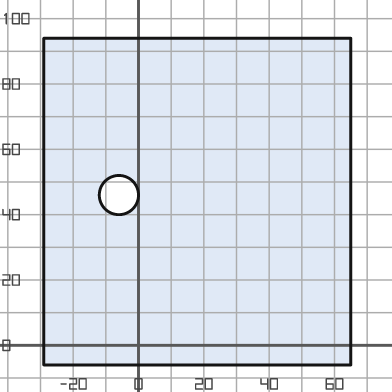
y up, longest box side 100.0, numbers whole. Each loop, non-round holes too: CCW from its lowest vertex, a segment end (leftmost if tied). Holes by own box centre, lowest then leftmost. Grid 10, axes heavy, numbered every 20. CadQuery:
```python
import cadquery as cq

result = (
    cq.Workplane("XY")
    .moveTo(-29.0, -6.0)
    .lineTo(65.0, -6.0)
    .lineTo(65.0, 94.0)
    .lineTo(-29.0, 94.0)
    .close()
    .moveTo(-6.0, 46.0)
    .circle(6.0)
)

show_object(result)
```